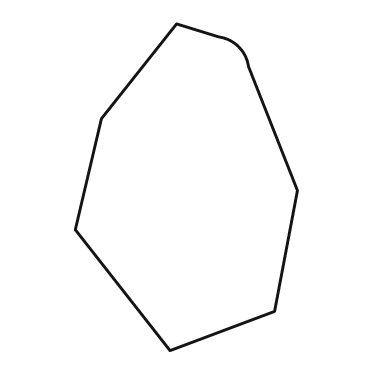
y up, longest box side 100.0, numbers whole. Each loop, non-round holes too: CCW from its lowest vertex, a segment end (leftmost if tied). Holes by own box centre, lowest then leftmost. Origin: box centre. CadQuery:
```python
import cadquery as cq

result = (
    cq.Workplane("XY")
    .moveTo(-5.0, -50.0)
    .lineTo(27.0, -38.0)
    .lineTo(34.0, -1.0)
    .lineTo(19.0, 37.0)
    .threePointArc((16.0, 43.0), (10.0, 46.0))
    .lineTo(-3.0, 50.0)
    .lineTo(-26.0, 21.0)
    .lineTo(-34.0, -13.0)
    .close()
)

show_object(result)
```